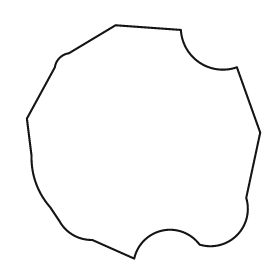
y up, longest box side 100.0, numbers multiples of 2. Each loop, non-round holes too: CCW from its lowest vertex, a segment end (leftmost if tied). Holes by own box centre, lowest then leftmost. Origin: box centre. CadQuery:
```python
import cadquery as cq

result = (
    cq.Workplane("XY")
    .moveTo(-4.0, -50.0)
    .threePointArc((8.0, -38.0), (24.0, -44.0))
    .threePointArc((40.0, -40.0), (44.0, -24.0))
    .lineTo(50.0, 4.0)
    .lineTo(40.0, 32.0)
    .threePointArc((24.0, 34.0), (16.0, 48.0))
    .lineTo(-12.0, 50.0)
    .lineTo(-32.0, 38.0)
    .threePointArc((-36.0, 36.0), (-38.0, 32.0))
    .lineTo(-50.0, 10.0)
    .lineTo(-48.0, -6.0)
    .threePointArc((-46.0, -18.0), (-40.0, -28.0))
    .lineTo(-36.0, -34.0)
    .threePointArc((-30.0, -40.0), (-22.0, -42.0))
    .close()
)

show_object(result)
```